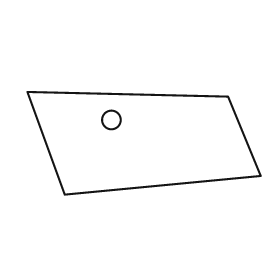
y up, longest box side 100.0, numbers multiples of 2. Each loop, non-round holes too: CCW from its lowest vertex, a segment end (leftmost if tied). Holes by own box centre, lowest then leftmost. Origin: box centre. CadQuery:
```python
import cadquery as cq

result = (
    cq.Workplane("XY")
    .moveTo(-34.0, -22.0)
    .lineTo(50.0, -14.0)
    .lineTo(36.0, 20.0)
    .lineTo(-50.0, 22.0)
    .close()
    .moveTo(-14.0, 10.0)
    .circle(4.0)
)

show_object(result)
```